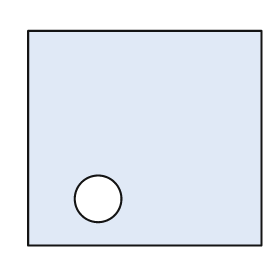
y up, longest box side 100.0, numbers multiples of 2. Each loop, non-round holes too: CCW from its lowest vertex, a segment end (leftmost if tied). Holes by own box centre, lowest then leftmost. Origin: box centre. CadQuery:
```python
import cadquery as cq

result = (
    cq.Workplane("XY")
    .moveTo(-50.0, -46.0)
    .lineTo(50.0, -46.0)
    .lineTo(50.0, 46.0)
    .lineTo(-50.0, 46.0)
    .close()
    .moveTo(-20.0, -26.0)
    .circle(10.0)
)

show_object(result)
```